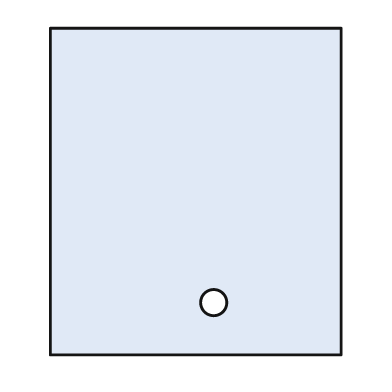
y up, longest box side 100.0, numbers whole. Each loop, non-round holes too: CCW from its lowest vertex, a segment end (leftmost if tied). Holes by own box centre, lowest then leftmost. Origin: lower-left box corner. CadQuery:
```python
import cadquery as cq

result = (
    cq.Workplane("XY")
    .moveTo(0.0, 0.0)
    .lineTo(89.0, 0.0)
    .lineTo(89.0, 100.0)
    .lineTo(0.0, 100.0)
    .close()
    .moveTo(50.0, 16.0)
    .circle(4.0)
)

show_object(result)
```